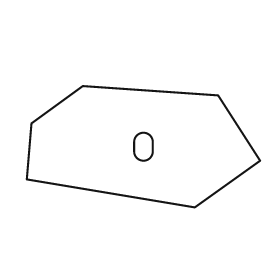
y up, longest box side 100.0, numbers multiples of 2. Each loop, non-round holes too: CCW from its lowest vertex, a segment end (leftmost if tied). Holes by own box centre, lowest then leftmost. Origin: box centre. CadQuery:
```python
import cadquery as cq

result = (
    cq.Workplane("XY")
    .moveTo(22.0, -26.0)
    .lineTo(50.0, -6.0)
    .lineTo(32.0, 22.0)
    .lineTo(-26.0, 26.0)
    .lineTo(-48.0, 10.0)
    .lineTo(-50.0, -14.0)
    .close()
    .moveTo(-4.0, -2.0)
    .threePointArc((0.0, -6.0), (4.0, -2.0))
    .lineTo(4.0, 2.0)
    .threePointArc((0.0, 6.0), (-4.0, 2.0))
    .close()
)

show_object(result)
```